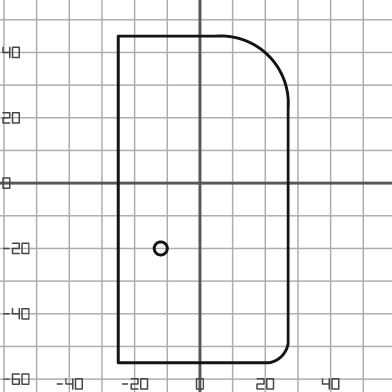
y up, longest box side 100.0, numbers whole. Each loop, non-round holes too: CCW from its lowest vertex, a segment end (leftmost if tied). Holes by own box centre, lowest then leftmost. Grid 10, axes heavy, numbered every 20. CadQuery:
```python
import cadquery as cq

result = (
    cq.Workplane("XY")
    .moveTo(-25.0, -55.0)
    .lineTo(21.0, -55.0)
    .threePointArc((25.0, -53.0), (27.0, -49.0))
    .lineTo(27.0, 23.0)
    .threePointArc((21.0, 39.0), (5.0, 45.0))
    .lineTo(-25.0, 45.0)
    .close()
    .moveTo(-12.0, -20.0)
    .circle(2.0)
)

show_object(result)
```